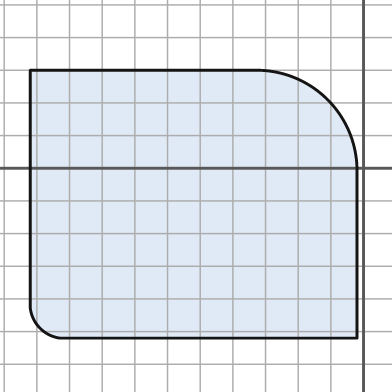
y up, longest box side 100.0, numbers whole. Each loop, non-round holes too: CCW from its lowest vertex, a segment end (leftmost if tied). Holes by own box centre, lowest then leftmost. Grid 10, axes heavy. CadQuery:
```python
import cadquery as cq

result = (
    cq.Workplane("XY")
    .moveTo(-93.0, -52.0)
    .lineTo(-2.0, -52.0)
    .lineTo(-2.0, 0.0)
    .threePointArc((-11.0, 21.0), (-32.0, 30.0))
    .lineTo(-102.0, 30.0)
    .lineTo(-102.0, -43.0)
    .threePointArc((-99.0, -49.0), (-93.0, -52.0))
    .close()
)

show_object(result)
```